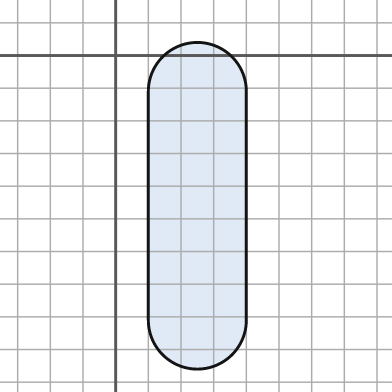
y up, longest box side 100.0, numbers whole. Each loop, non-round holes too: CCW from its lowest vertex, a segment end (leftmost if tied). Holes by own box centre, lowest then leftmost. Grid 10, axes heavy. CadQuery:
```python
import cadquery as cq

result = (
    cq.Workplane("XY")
    .moveTo(10.0, -81.0)
    .threePointArc((25.0, -96.0), (40.0, -81.0))
    .lineTo(40.0, -11.0)
    .threePointArc((25.0, 4.0), (10.0, -11.0))
    .close()
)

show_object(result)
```